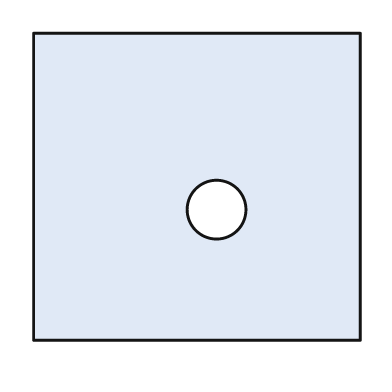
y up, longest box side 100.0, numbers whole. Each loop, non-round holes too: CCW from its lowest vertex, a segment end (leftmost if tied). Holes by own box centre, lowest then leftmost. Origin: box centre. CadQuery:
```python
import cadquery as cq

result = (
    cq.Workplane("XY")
    .moveTo(-50.0, -47.0)
    .lineTo(50.0, -47.0)
    .lineTo(50.0, 47.0)
    .lineTo(-50.0, 47.0)
    .close()
    .moveTo(6.0, -7.0)
    .circle(9.0)
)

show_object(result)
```